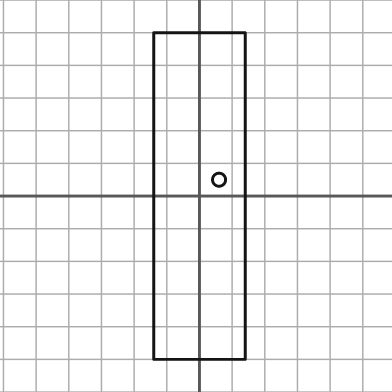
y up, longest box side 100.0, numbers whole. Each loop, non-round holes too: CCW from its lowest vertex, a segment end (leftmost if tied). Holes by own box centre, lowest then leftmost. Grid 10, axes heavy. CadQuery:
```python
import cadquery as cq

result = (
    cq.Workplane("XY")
    .moveTo(-14.0, -50.0)
    .lineTo(14.0, -50.0)
    .lineTo(14.0, 50.0)
    .lineTo(-14.0, 50.0)
    .close()
    .moveTo(6.0, 5.0)
    .circle(2.0)
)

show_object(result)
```